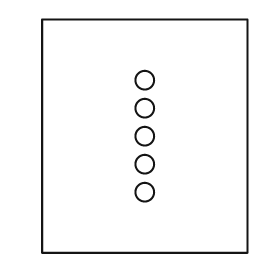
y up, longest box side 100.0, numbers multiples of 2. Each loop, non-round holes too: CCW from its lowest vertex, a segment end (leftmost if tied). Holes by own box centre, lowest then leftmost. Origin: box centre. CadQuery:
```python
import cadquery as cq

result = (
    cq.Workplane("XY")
    .moveTo(-44.0, -50.0)
    .lineTo(44.0, -50.0)
    .lineTo(44.0, 50.0)
    .lineTo(-44.0, 50.0)
    .close()
    .moveTo(0.0, -24.0)
    .circle(4.0)
    .moveTo(0.0, -12.0)
    .circle(4.0)
    .moveTo(0.0, 0.0)
    .circle(4.0)
    .moveTo(0.0, 12.0)
    .circle(4.0)
    .moveTo(0.0, 24.0)
    .circle(4.0)
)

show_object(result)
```